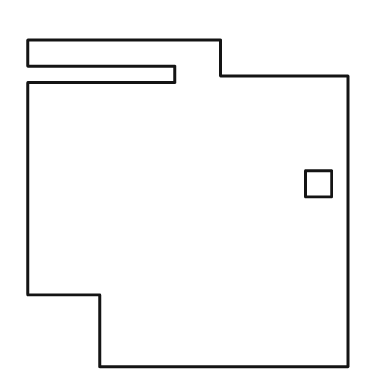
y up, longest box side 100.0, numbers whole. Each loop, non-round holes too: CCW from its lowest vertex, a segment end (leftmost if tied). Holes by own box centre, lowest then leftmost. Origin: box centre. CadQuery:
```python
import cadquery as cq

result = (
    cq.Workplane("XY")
    .moveTo(-27.0, -50.0)
    .lineTo(49.0, -50.0)
    .lineTo(49.0, 39.0)
    .lineTo(10.0, 39.0)
    .lineTo(10.0, 50.0)
    .lineTo(-49.0, 50.0)
    .lineTo(-49.0, 42.0)
    .lineTo(-4.0, 42.0)
    .lineTo(-4.0, 37.0)
    .lineTo(-49.0, 37.0)
    .lineTo(-49.0, -28.0)
    .lineTo(-27.0, -28.0)
    .close()
    .moveTo(36.0, 2.0)
    .lineTo(44.0, 2.0)
    .lineTo(44.0, 10.0)
    .lineTo(36.0, 10.0)
    .close()
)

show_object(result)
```